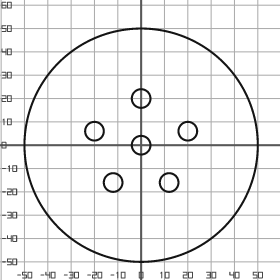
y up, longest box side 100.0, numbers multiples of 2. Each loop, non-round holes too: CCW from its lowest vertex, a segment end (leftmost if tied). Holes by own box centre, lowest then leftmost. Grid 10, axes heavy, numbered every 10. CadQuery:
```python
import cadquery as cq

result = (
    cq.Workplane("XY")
    .moveTo(0.0, 0.0)
    .circle(50.0)
    .moveTo(-12.0, -16.0)
    .circle(4.0)
    .moveTo(12.0, -16.0)
    .circle(4.0)
    .moveTo(0.0, 0.0)
    .circle(4.0)
    .moveTo(-20.0, 6.0)
    .circle(4.0)
    .moveTo(20.0, 6.0)
    .circle(4.0)
    .moveTo(0.0, 20.0)
    .circle(4.0)
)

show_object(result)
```